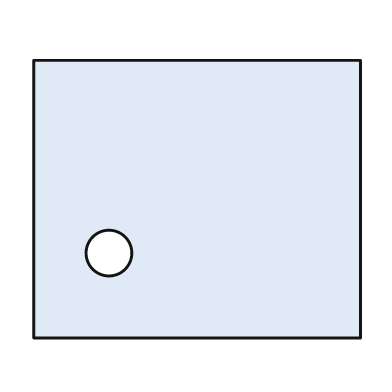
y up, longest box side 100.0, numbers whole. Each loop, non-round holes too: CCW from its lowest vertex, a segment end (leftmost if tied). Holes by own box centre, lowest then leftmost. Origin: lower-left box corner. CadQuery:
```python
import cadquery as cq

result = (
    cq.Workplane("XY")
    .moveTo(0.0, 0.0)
    .lineTo(100.0, 0.0)
    .lineTo(100.0, 85.0)
    .lineTo(0.0, 85.0)
    .close()
    .moveTo(23.0, 26.0)
    .circle(7.0)
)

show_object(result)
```